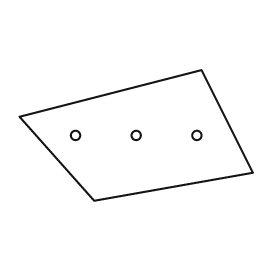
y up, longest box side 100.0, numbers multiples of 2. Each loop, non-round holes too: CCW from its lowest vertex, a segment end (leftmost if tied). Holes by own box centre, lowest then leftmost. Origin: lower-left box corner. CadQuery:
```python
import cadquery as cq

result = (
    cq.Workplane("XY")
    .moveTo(32.0, 0.0)
    .lineTo(100.0, 12.0)
    .lineTo(78.0, 56.0)
    .lineTo(0.0, 36.0)
    .close()
    .moveTo(24.0, 28.0)
    .circle(2.0)
    .moveTo(50.0, 28.0)
    .circle(2.0)
    .moveTo(76.0, 28.0)
    .circle(2.0)
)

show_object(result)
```